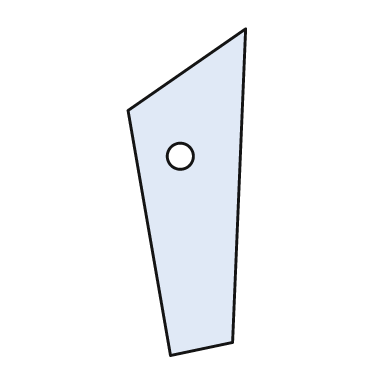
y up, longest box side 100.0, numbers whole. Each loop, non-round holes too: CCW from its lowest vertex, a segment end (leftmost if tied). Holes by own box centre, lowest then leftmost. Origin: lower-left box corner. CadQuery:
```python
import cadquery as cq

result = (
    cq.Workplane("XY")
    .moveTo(13.0, 0.0)
    .lineTo(32.0, 4.0)
    .lineTo(36.0, 100.0)
    .lineTo(0.0, 75.0)
    .close()
    .moveTo(16.0, 61.0)
    .circle(4.0)
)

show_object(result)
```